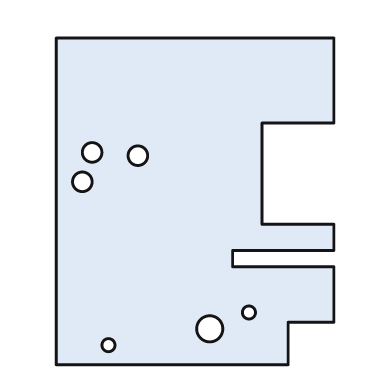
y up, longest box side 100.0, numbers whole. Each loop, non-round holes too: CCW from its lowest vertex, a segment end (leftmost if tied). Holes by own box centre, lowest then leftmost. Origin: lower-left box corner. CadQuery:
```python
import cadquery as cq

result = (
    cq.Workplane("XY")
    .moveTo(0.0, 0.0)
    .lineTo(71.0, 0.0)
    .lineTo(71.0, 13.0)
    .lineTo(85.0, 13.0)
    .lineTo(85.0, 30.0)
    .lineTo(54.0, 30.0)
    .lineTo(54.0, 35.0)
    .lineTo(85.0, 35.0)
    .lineTo(85.0, 43.0)
    .lineTo(63.0, 43.0)
    .lineTo(63.0, 74.0)
    .lineTo(85.0, 74.0)
    .lineTo(85.0, 100.0)
    .lineTo(0.0, 100.0)
    .close()
    .moveTo(16.0, 6.0)
    .circle(2.0)
    .moveTo(47.0, 11.0)
    .circle(4.0)
    .moveTo(59.0, 16.0)
    .circle(2.0)
    .moveTo(8.0, 56.0)
    .circle(3.0)
    .moveTo(25.0, 64.0)
    .circle(3.0)
    .moveTo(11.0, 65.0)
    .circle(3.0)
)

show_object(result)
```